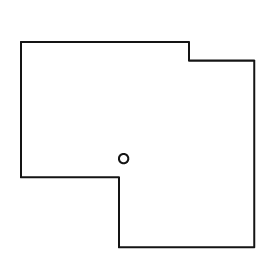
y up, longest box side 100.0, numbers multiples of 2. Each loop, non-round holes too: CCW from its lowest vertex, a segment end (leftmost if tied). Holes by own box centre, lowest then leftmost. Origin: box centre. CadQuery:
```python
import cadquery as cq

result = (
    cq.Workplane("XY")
    .moveTo(-8.0, -44.0)
    .lineTo(50.0, -44.0)
    .lineTo(50.0, 36.0)
    .lineTo(22.0, 36.0)
    .lineTo(22.0, 44.0)
    .lineTo(-50.0, 44.0)
    .lineTo(-50.0, -14.0)
    .lineTo(-8.0, -14.0)
    .close()
    .moveTo(-6.0, -6.0)
    .circle(2.0)
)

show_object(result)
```